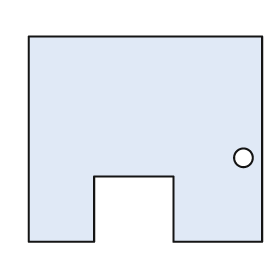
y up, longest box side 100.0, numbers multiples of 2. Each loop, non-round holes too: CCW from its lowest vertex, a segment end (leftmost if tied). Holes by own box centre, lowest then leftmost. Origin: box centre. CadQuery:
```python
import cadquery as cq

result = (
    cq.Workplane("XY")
    .moveTo(-50.0, -44.0)
    .lineTo(-22.0, -44.0)
    .lineTo(-22.0, -16.0)
    .lineTo(12.0, -16.0)
    .lineTo(12.0, -44.0)
    .lineTo(50.0, -44.0)
    .lineTo(50.0, 44.0)
    .lineTo(-50.0, 44.0)
    .close()
    .moveTo(42.0, -8.0)
    .circle(4.0)
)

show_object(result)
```